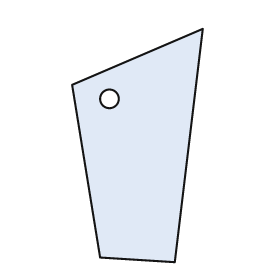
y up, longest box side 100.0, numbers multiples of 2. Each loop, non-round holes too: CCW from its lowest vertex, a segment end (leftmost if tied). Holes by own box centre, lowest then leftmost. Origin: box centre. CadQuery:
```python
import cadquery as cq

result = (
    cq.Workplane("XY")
    .moveTo(16.0, -50.0)
    .lineTo(28.0, 50.0)
    .lineTo(-28.0, 26.0)
    .lineTo(-16.0, -48.0)
    .close()
    .moveTo(-12.0, 20.0)
    .circle(4.0)
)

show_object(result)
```